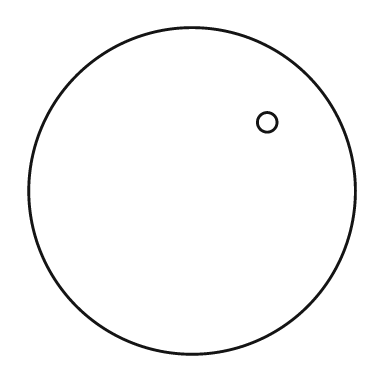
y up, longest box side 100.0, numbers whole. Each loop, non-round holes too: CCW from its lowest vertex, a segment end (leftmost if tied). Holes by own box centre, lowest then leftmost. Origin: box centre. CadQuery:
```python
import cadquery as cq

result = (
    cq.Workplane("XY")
    .moveTo(0.0, 0.0)
    .circle(50.0)
    .moveTo(23.0, 21.0)
    .circle(3.0)
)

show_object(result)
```